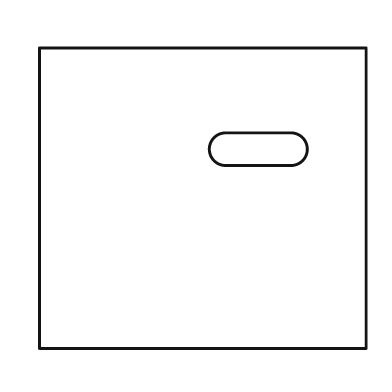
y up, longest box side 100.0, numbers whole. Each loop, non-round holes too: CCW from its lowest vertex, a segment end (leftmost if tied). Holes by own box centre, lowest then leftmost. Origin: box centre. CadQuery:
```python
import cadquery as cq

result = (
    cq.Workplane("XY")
    .moveTo(-50.0, -46.0)
    .lineTo(50.0, -46.0)
    .lineTo(50.0, 46.0)
    .lineTo(-50.0, 46.0)
    .close()
    .moveTo(7.0, 10.0)
    .lineTo(27.0, 10.0)
    .threePointArc((32.0, 15.0), (27.0, 20.0))
    .lineTo(7.0, 20.0)
    .threePointArc((2.0, 15.0), (7.0, 10.0))
    .close()
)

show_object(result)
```